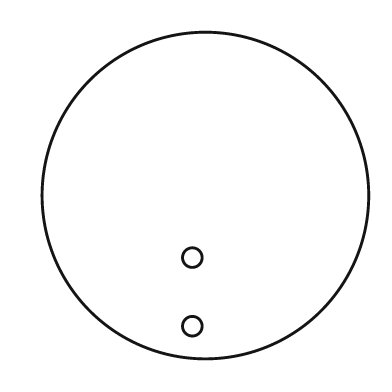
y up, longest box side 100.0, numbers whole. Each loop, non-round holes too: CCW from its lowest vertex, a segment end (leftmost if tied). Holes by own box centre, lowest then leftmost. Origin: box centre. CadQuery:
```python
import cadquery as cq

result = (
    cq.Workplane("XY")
    .moveTo(0.0, 0.0)
    .circle(50.0)
    .moveTo(-4.0, -40.0)
    .circle(3.0)
    .moveTo(-4.0, -19.0)
    .circle(3.0)
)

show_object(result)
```